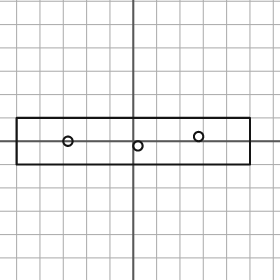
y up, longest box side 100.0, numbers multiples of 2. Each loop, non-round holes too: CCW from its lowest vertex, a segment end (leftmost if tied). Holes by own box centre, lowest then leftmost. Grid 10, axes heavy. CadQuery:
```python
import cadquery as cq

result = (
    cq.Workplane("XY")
    .moveTo(-50.0, -10.0)
    .lineTo(50.0, -10.0)
    .lineTo(50.0, 10.0)
    .lineTo(-50.0, 10.0)
    .close()
    .moveTo(2.0, -2.0)
    .circle(2.0)
    .moveTo(-28.0, 0.0)
    .circle(2.0)
    .moveTo(28.0, 2.0)
    .circle(2.0)
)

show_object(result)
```